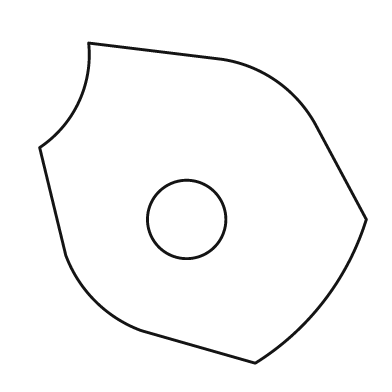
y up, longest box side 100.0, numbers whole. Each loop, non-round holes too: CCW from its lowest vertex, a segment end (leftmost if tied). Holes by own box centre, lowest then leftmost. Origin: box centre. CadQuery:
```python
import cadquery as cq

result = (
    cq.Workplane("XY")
    .moveTo(16.0, -49.0)
    .threePointArc((37.0, -30.0), (50.0, -5.0))
    .lineTo(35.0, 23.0)
    .threePointArc((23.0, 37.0), (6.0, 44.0))
    .lineTo(-35.0, 49.0)
    .threePointArc((-38.0, 31.0), (-50.0, 17.0))
    .lineTo(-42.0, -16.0)
    .threePointArc((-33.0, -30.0), (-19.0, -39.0))
    .close()
    .moveTo(-5.0, -5.0)
    .circle(12.0)
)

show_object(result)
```